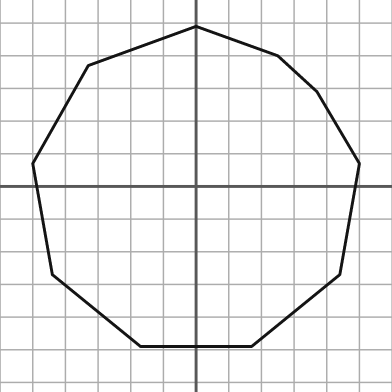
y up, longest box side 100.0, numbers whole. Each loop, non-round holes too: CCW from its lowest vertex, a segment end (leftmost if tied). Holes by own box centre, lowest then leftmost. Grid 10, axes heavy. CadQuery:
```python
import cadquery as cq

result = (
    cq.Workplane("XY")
    .moveTo(-17.0, -49.0)
    .lineTo(17.0, -49.0)
    .lineTo(44.0, -27.0)
    .lineTo(50.0, 7.0)
    .lineTo(37.0, 29.0)
    .lineTo(25.0, 40.0)
    .lineTo(0.0, 49.0)
    .lineTo(-33.0, 37.0)
    .lineTo(-50.0, 7.0)
    .lineTo(-44.0, -27.0)
    .close()
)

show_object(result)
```